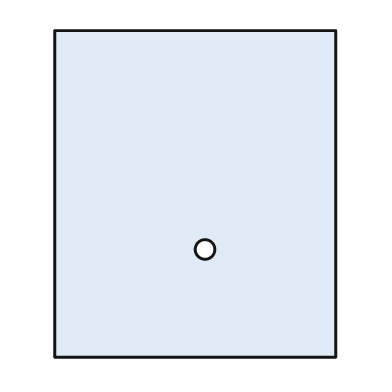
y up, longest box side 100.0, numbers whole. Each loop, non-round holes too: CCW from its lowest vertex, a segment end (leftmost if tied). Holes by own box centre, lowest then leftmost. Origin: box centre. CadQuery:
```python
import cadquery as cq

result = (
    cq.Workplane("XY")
    .moveTo(-43.0, -50.0)
    .lineTo(43.0, -50.0)
    .lineTo(43.0, 50.0)
    .lineTo(-43.0, 50.0)
    .close()
    .moveTo(3.0, -17.0)
    .circle(3.0)
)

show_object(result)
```